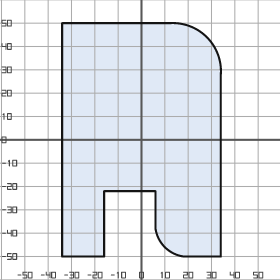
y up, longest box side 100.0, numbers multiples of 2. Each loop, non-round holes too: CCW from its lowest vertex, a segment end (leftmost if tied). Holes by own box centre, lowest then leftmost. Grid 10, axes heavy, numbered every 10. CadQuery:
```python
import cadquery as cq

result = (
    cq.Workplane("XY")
    .moveTo(-34.0, -50.0)
    .lineTo(-16.0, -50.0)
    .lineTo(-16.0, -22.0)
    .lineTo(6.0, -22.0)
    .lineTo(6.0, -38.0)
    .threePointArc((10.0, -46.0), (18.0, -50.0))
    .lineTo(34.0, -50.0)
    .lineTo(34.0, 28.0)
    .threePointArc((28.0, 44.0), (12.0, 50.0))
    .lineTo(-34.0, 50.0)
    .close()
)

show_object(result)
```